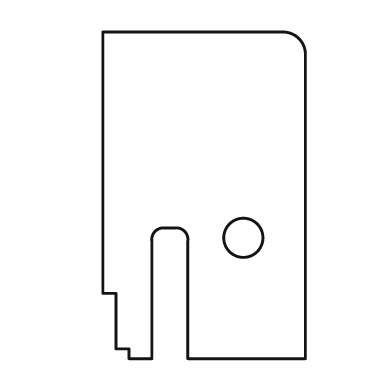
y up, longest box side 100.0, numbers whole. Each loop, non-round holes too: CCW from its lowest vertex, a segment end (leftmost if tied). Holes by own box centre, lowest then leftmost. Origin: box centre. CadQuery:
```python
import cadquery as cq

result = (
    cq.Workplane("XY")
    .moveTo(-23.0, -50.0)
    .lineTo(-16.0, -50.0)
    .lineTo(-16.0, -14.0)
    .threePointArc((-15.0, -11.0), (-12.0, -10.0))
    .lineTo(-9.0, -10.0)
    .threePointArc((-6.0, -11.0), (-5.0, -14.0))
    .lineTo(-5.0, -50.0)
    .lineTo(31.0, -50.0)
    .lineTo(31.0, 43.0)
    .threePointArc((29.0, 48.0), (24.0, 50.0))
    .lineTo(-31.0, 50.0)
    .lineTo(-31.0, -30.0)
    .lineTo(-27.0, -30.0)
    .lineTo(-27.0, -47.0)
    .lineTo(-23.0, -47.0)
    .close()
    .moveTo(12.0, -13.0)
    .circle(6.0)
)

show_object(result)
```